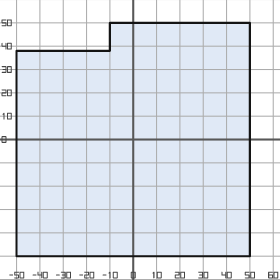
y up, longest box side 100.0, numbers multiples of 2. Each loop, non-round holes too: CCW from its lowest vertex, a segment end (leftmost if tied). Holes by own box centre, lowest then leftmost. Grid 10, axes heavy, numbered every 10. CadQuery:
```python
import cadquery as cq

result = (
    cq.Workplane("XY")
    .moveTo(-50.0, -50.0)
    .lineTo(50.0, -50.0)
    .lineTo(50.0, 50.0)
    .lineTo(-10.0, 50.0)
    .lineTo(-10.0, 38.0)
    .lineTo(-50.0, 38.0)
    .close()
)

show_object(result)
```